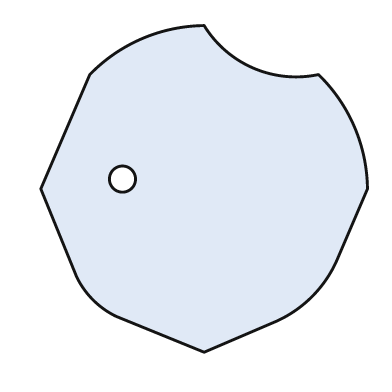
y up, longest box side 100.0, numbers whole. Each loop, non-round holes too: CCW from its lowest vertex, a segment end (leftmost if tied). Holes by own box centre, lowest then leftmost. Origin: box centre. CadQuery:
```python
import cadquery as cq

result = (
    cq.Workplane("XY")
    .moveTo(0.0, -50.0)
    .lineTo(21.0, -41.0)
    .threePointArc((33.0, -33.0), (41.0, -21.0))
    .lineTo(50.0, 0.0)
    .threePointArc((46.0, 19.0), (35.0, 35.0))
    .threePointArc((15.0, 37.0), (0.0, 50.0))
    .threePointArc((-19.0, 46.0), (-35.0, 35.0))
    .lineTo(-50.0, 0.0)
    .lineTo(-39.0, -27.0)
    .threePointArc((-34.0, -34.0), (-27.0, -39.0))
    .close()
    .moveTo(-25.0, 3.0)
    .circle(4.0)
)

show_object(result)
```